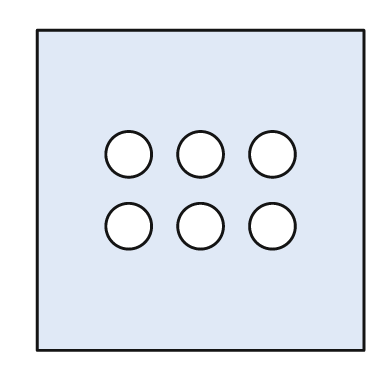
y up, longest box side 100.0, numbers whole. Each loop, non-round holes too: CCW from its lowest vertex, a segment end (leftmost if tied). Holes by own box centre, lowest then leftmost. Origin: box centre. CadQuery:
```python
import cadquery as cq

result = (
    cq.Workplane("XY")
    .moveTo(-50.0, -49.0)
    .lineTo(50.0, -49.0)
    .lineTo(50.0, 49.0)
    .lineTo(-50.0, 49.0)
    .close()
    .moveTo(-22.0, -11.0)
    .circle(7.0)
    .moveTo(0.0, -11.0)
    .circle(7.0)
    .moveTo(22.0, -11.0)
    .circle(7.0)
    .moveTo(-22.0, 11.0)
    .circle(7.0)
    .moveTo(0.0, 11.0)
    .circle(7.0)
    .moveTo(22.0, 11.0)
    .circle(7.0)
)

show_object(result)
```